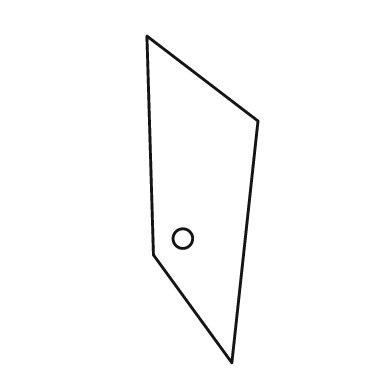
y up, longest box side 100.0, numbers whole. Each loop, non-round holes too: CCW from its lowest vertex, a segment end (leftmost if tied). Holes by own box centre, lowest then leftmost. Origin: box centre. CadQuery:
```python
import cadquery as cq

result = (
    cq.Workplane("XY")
    .moveTo(9.0, -50.0)
    .lineTo(17.0, 24.0)
    .lineTo(-17.0, 50.0)
    .lineTo(-15.0, -17.0)
    .close()
    .moveTo(-6.0, -12.0)
    .circle(3.0)
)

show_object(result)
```